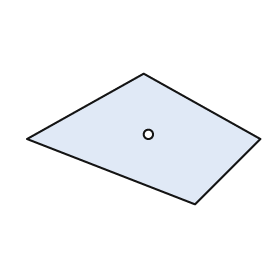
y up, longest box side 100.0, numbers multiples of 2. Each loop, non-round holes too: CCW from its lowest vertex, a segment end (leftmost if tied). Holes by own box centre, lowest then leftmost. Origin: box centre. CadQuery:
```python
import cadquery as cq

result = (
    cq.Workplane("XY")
    .moveTo(22.0, -28.0)
    .lineTo(50.0, 0.0)
    .lineTo(0.0, 28.0)
    .lineTo(-50.0, 0.0)
    .close()
    .moveTo(2.0, 2.0)
    .circle(2.0)
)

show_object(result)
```